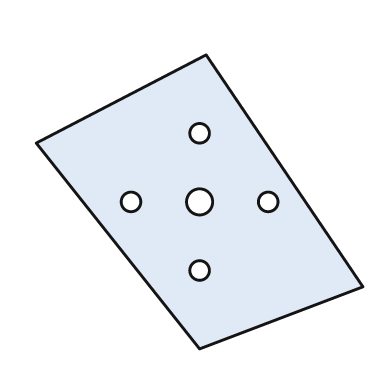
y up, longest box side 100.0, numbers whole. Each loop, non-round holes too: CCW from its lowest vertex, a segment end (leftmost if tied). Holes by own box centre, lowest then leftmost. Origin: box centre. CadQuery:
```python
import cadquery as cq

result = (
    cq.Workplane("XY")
    .moveTo(0.0, -45.0)
    .lineTo(50.0, -26.0)
    .lineTo(2.0, 45.0)
    .lineTo(-50.0, 18.0)
    .close()
    .moveTo(0.0, -21.0)
    .circle(3.0)
    .moveTo(-21.0, 0.0)
    .circle(3.0)
    .moveTo(0.0, 0.0)
    .circle(4.0)
    .moveTo(21.0, 0.0)
    .circle(3.0)
    .moveTo(0.0, 21.0)
    .circle(3.0)
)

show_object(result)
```